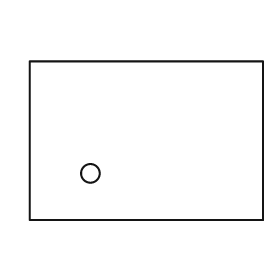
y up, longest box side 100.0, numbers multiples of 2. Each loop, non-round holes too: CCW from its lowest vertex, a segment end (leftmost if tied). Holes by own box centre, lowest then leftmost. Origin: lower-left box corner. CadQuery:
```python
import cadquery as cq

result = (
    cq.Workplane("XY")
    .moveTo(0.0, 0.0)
    .lineTo(100.0, 0.0)
    .lineTo(100.0, 68.0)
    .lineTo(0.0, 68.0)
    .close()
    .moveTo(26.0, 20.0)
    .circle(4.0)
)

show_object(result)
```